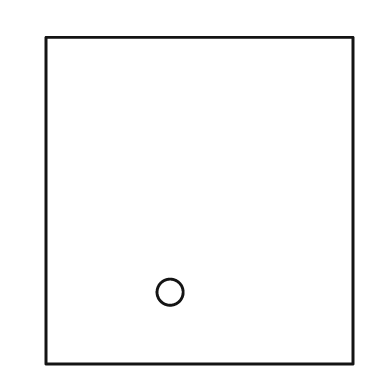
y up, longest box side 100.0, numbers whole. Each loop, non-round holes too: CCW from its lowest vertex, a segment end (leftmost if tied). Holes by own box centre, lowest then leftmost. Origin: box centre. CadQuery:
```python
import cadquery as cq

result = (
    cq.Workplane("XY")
    .moveTo(-47.0, -50.0)
    .lineTo(47.0, -50.0)
    .lineTo(47.0, 50.0)
    .lineTo(-47.0, 50.0)
    .close()
    .moveTo(-9.0, -28.0)
    .circle(4.0)
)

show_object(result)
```